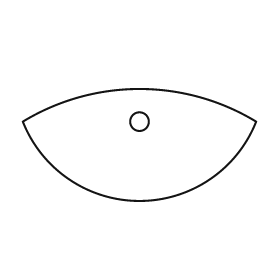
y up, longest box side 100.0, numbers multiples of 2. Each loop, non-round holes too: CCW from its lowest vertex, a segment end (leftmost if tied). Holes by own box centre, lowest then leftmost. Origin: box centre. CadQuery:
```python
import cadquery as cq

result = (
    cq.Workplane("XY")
    .moveTo(-50.0, 10.0)
    .threePointArc((0.0, -24.0), (50.0, 10.0))
    .threePointArc((0.0, 24.0), (-50.0, 10.0))
    .close()
    .moveTo(0.0, 10.0)
    .circle(4.0)
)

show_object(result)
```